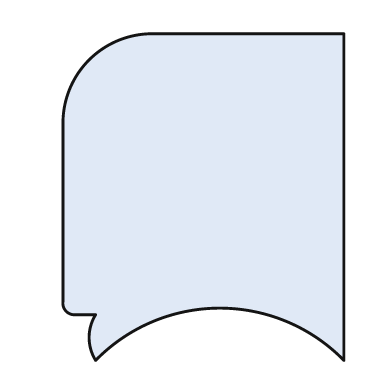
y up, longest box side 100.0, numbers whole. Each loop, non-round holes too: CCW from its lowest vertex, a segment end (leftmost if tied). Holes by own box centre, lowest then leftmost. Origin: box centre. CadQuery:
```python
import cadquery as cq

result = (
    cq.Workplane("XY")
    .moveTo(-33.0, -50.0)
    .threePointArc((5.0, -34.0), (43.0, -50.0))
    .lineTo(43.0, 50.0)
    .lineTo(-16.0, 50.0)
    .threePointArc((-35.0, 42.0), (-43.0, 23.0))
    .lineTo(-43.0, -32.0)
    .threePointArc((-42.0, -35.0), (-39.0, -36.0))
    .lineTo(-33.0, -36.0)
    .threePointArc((-35.0, -43.0), (-33.0, -50.0))
    .close()
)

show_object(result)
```